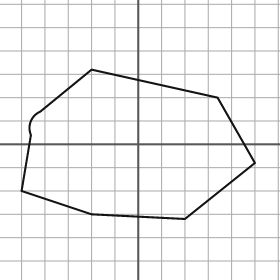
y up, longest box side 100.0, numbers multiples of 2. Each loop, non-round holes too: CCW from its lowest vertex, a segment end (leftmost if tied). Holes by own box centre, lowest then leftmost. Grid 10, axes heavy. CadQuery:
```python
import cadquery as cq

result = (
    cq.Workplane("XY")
    .moveTo(20.0, -32.0)
    .lineTo(50.0, -8.0)
    .lineTo(34.0, 20.0)
    .lineTo(-20.0, 32.0)
    .lineTo(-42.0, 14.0)
    .threePointArc((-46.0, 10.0), (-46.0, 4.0))
    .lineTo(-50.0, -20.0)
    .lineTo(-20.0, -30.0)
    .close()
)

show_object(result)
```